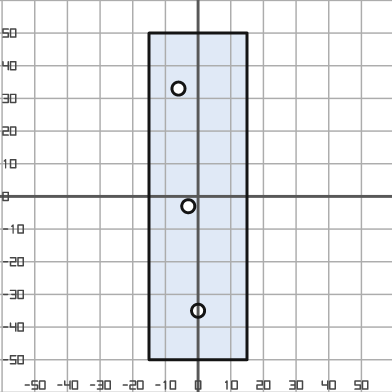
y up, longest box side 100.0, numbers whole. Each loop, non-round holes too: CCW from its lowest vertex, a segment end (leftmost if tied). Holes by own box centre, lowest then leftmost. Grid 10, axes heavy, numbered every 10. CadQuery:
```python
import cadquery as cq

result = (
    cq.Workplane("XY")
    .moveTo(-15.0, -50.0)
    .lineTo(15.0, -50.0)
    .lineTo(15.0, 50.0)
    .lineTo(-15.0, 50.0)
    .close()
    .moveTo(0.0, -35.0)
    .circle(2.0)
    .moveTo(-3.0, -3.0)
    .circle(2.0)
    .moveTo(-6.0, 33.0)
    .circle(2.0)
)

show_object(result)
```